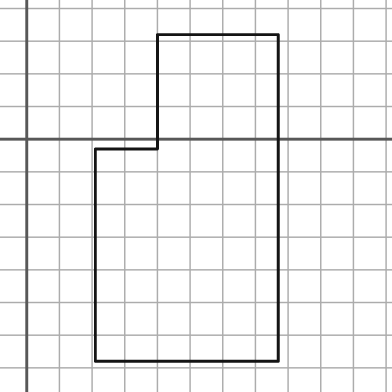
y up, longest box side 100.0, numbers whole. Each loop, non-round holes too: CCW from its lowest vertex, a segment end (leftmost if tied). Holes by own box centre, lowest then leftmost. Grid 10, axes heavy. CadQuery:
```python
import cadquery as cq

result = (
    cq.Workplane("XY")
    .moveTo(21.0, -68.0)
    .lineTo(77.0, -68.0)
    .lineTo(77.0, 32.0)
    .lineTo(40.0, 32.0)
    .lineTo(40.0, -3.0)
    .lineTo(21.0, -3.0)
    .close()
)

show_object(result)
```